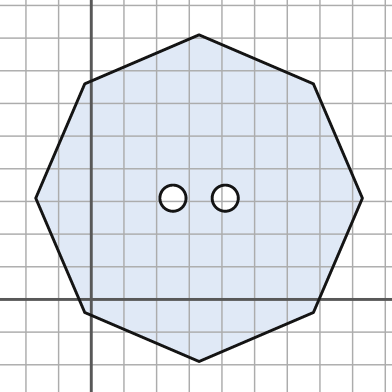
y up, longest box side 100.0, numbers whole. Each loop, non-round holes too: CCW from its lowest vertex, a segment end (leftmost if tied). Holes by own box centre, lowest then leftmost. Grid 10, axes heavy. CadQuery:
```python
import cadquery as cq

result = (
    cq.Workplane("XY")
    .moveTo(33.0, -19.0)
    .lineTo(68.0, -4.0)
    .lineTo(83.0, 31.0)
    .lineTo(68.0, 66.0)
    .lineTo(33.0, 81.0)
    .lineTo(-2.0, 66.0)
    .lineTo(-17.0, 31.0)
    .lineTo(-2.0, -4.0)
    .close()
    .moveTo(25.0, 31.0)
    .circle(4.0)
    .moveTo(41.0, 31.0)
    .circle(4.0)
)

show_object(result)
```